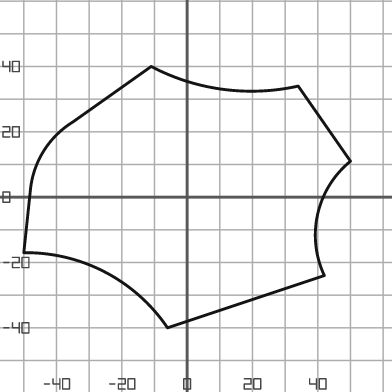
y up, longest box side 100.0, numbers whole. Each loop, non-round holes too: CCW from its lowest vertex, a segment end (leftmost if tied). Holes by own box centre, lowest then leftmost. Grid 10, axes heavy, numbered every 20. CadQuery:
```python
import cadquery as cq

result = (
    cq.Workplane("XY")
    .moveTo(-6.0, -40.0)
    .lineTo(42.0, -24.0)
    .threePointArc((40.0, -5.0), (50.0, 11.0))
    .lineTo(34.0, 34.0)
    .threePointArc((11.0, 33.0), (-11.0, 40.0))
    .lineTo(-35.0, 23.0)
    .threePointArc((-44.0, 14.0), (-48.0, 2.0))
    .lineTo(-50.0, -17.0)
    .threePointArc((-25.0, -23.0), (-6.0, -40.0))
    .close()
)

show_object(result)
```